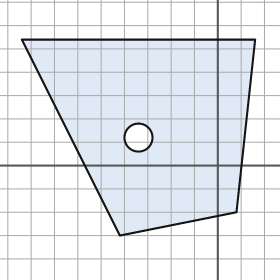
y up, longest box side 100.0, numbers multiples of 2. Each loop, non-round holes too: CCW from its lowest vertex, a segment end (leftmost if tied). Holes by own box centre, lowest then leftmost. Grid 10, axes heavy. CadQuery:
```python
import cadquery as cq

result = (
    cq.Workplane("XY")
    .moveTo(-42.0, -30.0)
    .lineTo(8.0, -20.0)
    .lineTo(16.0, 54.0)
    .lineTo(-84.0, 54.0)
    .close()
    .moveTo(-34.0, 12.0)
    .circle(6.0)
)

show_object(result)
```